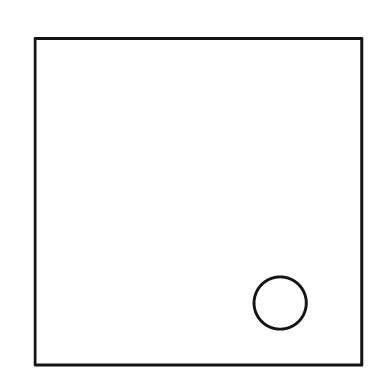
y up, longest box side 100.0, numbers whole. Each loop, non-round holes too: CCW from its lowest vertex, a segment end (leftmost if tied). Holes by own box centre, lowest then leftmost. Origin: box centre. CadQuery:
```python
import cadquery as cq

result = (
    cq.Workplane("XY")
    .moveTo(-50.0, -50.0)
    .lineTo(50.0, -50.0)
    .lineTo(50.0, 50.0)
    .lineTo(-50.0, 50.0)
    .close()
    .moveTo(25.0, -31.0)
    .circle(8.0)
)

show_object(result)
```